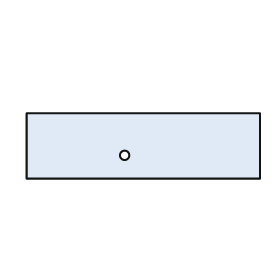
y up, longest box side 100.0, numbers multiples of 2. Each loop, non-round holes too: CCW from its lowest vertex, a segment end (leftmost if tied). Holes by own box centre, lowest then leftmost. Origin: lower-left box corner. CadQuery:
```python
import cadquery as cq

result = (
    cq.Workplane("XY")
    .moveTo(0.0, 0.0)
    .lineTo(100.0, 0.0)
    .lineTo(100.0, 28.0)
    .lineTo(0.0, 28.0)
    .close()
    .moveTo(42.0, 10.0)
    .circle(2.0)
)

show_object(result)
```